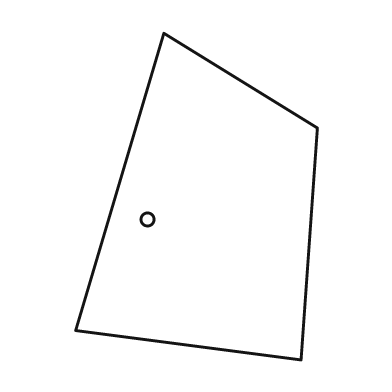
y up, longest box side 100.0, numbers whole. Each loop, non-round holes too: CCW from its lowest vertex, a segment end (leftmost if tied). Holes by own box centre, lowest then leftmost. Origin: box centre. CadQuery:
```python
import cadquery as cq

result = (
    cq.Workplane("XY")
    .moveTo(32.0, -50.0)
    .lineTo(37.0, 21.0)
    .lineTo(-10.0, 50.0)
    .lineTo(-37.0, -41.0)
    .close()
    .moveTo(-15.0, -7.0)
    .circle(2.0)
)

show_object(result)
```